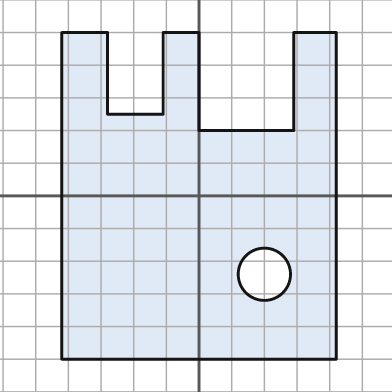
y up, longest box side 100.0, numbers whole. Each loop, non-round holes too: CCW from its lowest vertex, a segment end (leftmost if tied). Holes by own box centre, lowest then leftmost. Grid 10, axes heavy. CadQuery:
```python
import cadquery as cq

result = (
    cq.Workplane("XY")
    .moveTo(-42.0, -50.0)
    .lineTo(42.0, -50.0)
    .lineTo(42.0, 50.0)
    .lineTo(29.0, 50.0)
    .lineTo(29.0, 20.0)
    .lineTo(0.0, 20.0)
    .lineTo(0.0, 50.0)
    .lineTo(-11.0, 50.0)
    .lineTo(-11.0, 25.0)
    .lineTo(-28.0, 25.0)
    .lineTo(-28.0, 50.0)
    .lineTo(-42.0, 50.0)
    .close()
    .moveTo(20.0, -24.0)
    .circle(8.0)
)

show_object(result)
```